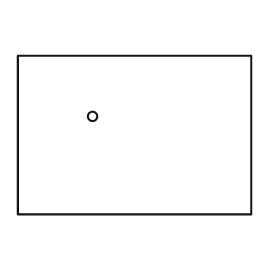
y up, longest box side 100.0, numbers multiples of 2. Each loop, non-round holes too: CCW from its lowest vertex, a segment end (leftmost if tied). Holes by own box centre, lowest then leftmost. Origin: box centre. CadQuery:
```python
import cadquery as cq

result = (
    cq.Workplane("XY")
    .moveTo(-50.0, -34.0)
    .lineTo(50.0, -34.0)
    .lineTo(50.0, 34.0)
    .lineTo(-50.0, 34.0)
    .close()
    .moveTo(-18.0, 8.0)
    .circle(2.0)
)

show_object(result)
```